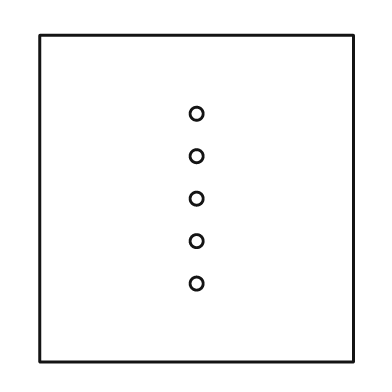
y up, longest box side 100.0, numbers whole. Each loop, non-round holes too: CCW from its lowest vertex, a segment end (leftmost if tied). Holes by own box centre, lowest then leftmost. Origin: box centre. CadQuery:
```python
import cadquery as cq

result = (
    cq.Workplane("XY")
    .moveTo(-48.0, -50.0)
    .lineTo(48.0, -50.0)
    .lineTo(48.0, 50.0)
    .lineTo(-48.0, 50.0)
    .close()
    .moveTo(0.0, -26.0)
    .circle(2.0)
    .moveTo(0.0, -13.0)
    .circle(2.0)
    .moveTo(0.0, 0.0)
    .circle(2.0)
    .moveTo(0.0, 13.0)
    .circle(2.0)
    .moveTo(0.0, 26.0)
    .circle(2.0)
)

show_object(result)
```